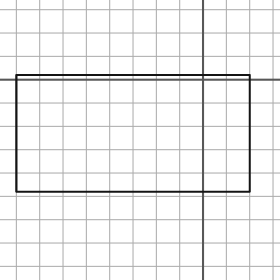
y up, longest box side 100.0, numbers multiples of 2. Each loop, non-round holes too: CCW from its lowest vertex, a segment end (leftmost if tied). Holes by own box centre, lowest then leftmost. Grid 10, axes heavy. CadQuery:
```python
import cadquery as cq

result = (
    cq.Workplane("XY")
    .moveTo(-80.0, -48.0)
    .lineTo(20.0, -48.0)
    .lineTo(20.0, 2.0)
    .lineTo(-80.0, 2.0)
    .close()
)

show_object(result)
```